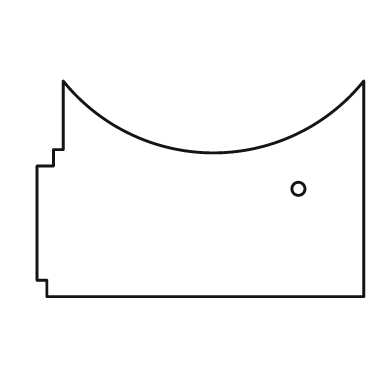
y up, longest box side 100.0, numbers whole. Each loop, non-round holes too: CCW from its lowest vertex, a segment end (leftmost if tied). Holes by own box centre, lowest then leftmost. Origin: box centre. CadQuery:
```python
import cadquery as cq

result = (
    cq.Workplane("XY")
    .moveTo(-47.0, -33.0)
    .lineTo(50.0, -33.0)
    .lineTo(50.0, 33.0)
    .threePointArc((4.0, 11.0), (-42.0, 33.0))
    .lineTo(-42.0, 12.0)
    .lineTo(-45.0, 12.0)
    .lineTo(-45.0, 7.0)
    .lineTo(-50.0, 7.0)
    .lineTo(-50.0, -28.0)
    .lineTo(-47.0, -28.0)
    .close()
    .moveTo(30.0, 0.0)
    .circle(2.0)
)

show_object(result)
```